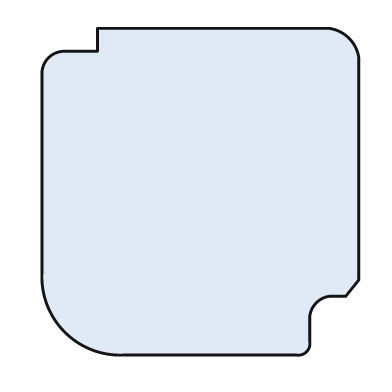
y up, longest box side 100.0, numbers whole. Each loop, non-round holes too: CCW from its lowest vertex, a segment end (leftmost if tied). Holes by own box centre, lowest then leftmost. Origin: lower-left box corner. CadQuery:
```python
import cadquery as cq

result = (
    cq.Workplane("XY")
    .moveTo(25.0, 0.0)
    .lineTo(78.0, 0.0)
    .threePointArc((81.0, 1.0), (82.0, 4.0))
    .lineTo(82.0, 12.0)
    .threePointArc((84.0, 16.0), (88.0, 18.0))
    .lineTo(93.0, 18.0)
    .lineTo(97.0, 23.0)
    .lineTo(97.0, 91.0)
    .threePointArc((94.0, 97.0), (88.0, 100.0))
    .lineTo(17.0, 100.0)
    .lineTo(17.0, 93.0)
    .lineTo(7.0, 93.0)
    .threePointArc((2.0, 91.0), (0.0, 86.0))
    .lineTo(0.0, 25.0)
    .threePointArc((7.0, 7.0), (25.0, 0.0))
    .close()
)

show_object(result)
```